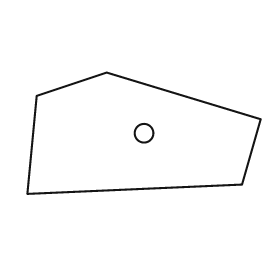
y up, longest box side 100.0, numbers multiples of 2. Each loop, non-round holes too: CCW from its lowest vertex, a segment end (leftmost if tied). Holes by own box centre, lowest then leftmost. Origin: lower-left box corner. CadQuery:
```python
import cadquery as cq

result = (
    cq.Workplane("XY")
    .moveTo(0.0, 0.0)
    .lineTo(92.0, 4.0)
    .lineTo(100.0, 32.0)
    .lineTo(34.0, 52.0)
    .lineTo(4.0, 42.0)
    .close()
    .moveTo(50.0, 26.0)
    .circle(4.0)
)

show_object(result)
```